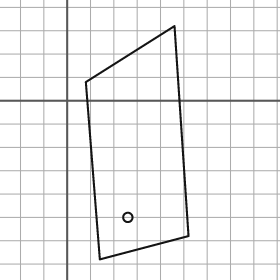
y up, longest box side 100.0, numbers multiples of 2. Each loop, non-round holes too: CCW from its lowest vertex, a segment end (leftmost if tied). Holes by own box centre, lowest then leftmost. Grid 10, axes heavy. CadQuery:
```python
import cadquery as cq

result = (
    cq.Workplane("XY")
    .moveTo(14.0, -68.0)
    .lineTo(52.0, -58.0)
    .lineTo(46.0, 32.0)
    .lineTo(8.0, 8.0)
    .close()
    .moveTo(26.0, -50.0)
    .circle(2.0)
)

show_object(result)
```